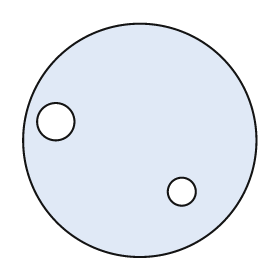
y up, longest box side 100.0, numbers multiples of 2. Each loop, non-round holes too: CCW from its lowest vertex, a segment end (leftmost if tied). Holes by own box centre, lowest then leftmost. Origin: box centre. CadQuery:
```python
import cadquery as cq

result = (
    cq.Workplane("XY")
    .moveTo(0.0, 0.0)
    .circle(50.0)
    .moveTo(18.0, -22.0)
    .circle(6.0)
    .moveTo(-36.0, 8.0)
    .circle(8.0)
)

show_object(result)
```